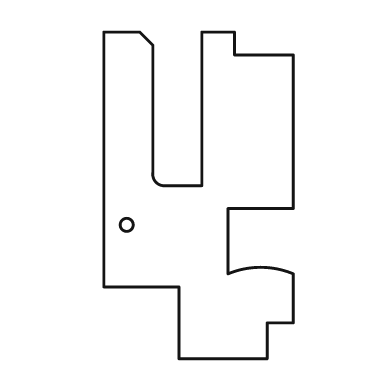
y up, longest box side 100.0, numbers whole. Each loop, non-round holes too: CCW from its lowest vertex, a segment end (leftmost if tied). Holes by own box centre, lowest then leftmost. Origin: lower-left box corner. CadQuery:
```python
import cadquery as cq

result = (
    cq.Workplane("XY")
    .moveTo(23.0, 0.0)
    .lineTo(50.0, 0.0)
    .lineTo(50.0, 11.0)
    .lineTo(58.0, 11.0)
    .lineTo(58.0, 26.0)
    .threePointArc((48.0, 28.0), (38.0, 26.0))
    .lineTo(38.0, 46.0)
    .lineTo(58.0, 46.0)
    .lineTo(58.0, 93.0)
    .lineTo(40.0, 93.0)
    .lineTo(40.0, 100.0)
    .lineTo(30.0, 100.0)
    .lineTo(30.0, 53.0)
    .lineTo(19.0, 53.0)
    .threePointArc((16.0, 54.0), (15.0, 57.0))
    .lineTo(15.0, 96.0)
    .lineTo(11.0, 100.0)
    .lineTo(0.0, 100.0)
    .lineTo(0.0, 22.0)
    .lineTo(23.0, 22.0)
    .close()
    .moveTo(7.0, 41.0)
    .circle(2.0)
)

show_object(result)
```